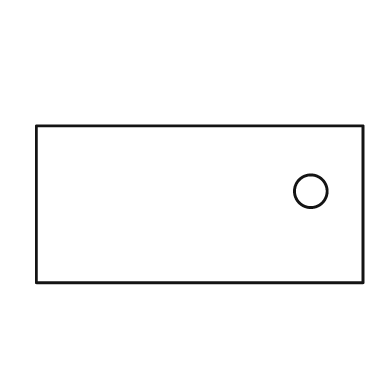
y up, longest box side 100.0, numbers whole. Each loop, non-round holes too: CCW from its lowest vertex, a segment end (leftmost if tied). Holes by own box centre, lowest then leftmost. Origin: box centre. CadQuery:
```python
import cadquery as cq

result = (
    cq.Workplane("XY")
    .moveTo(-50.0, -24.0)
    .lineTo(50.0, -24.0)
    .lineTo(50.0, 24.0)
    .lineTo(-50.0, 24.0)
    .close()
    .moveTo(34.0, 4.0)
    .circle(5.0)
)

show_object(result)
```